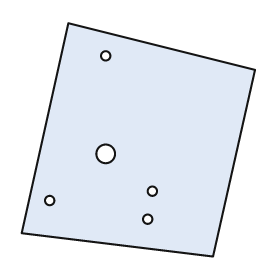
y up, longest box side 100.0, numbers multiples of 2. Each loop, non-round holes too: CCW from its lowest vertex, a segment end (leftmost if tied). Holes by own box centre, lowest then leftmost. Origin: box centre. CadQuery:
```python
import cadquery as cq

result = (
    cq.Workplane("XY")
    .moveTo(32.0, -50.0)
    .lineTo(50.0, 30.0)
    .lineTo(-30.0, 50.0)
    .lineTo(-50.0, -40.0)
    .close()
    .moveTo(4.0, -34.0)
    .circle(2.0)
    .moveTo(-38.0, -26.0)
    .circle(2.0)
    .moveTo(6.0, -22.0)
    .circle(2.0)
    .moveTo(-14.0, -6.0)
    .circle(4.0)
    .moveTo(-14.0, 36.0)
    .circle(2.0)
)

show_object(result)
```